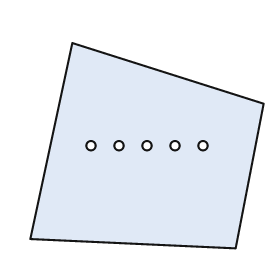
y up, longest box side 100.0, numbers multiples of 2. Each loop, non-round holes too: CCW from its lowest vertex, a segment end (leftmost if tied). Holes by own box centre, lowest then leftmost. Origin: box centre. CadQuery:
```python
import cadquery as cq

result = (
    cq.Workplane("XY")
    .moveTo(38.0, -44.0)
    .lineTo(50.0, 18.0)
    .lineTo(-32.0, 44.0)
    .lineTo(-50.0, -40.0)
    .close()
    .moveTo(-24.0, 0.0)
    .circle(2.0)
    .moveTo(-12.0, 0.0)
    .circle(2.0)
    .moveTo(0.0, 0.0)
    .circle(2.0)
    .moveTo(12.0, 0.0)
    .circle(2.0)
    .moveTo(24.0, 0.0)
    .circle(2.0)
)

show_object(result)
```